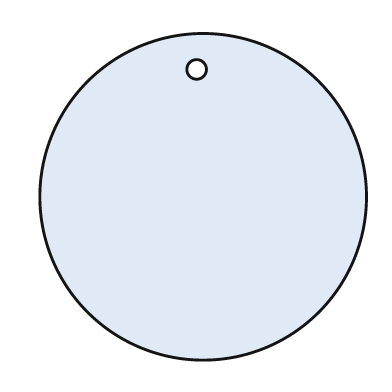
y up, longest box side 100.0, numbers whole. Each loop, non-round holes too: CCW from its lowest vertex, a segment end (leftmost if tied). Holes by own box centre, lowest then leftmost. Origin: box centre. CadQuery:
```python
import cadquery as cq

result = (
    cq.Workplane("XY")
    .moveTo(0.0, 0.0)
    .circle(50.0)
    .moveTo(-2.0, 39.0)
    .circle(3.0)
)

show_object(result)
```